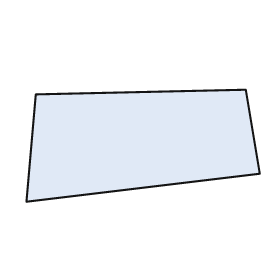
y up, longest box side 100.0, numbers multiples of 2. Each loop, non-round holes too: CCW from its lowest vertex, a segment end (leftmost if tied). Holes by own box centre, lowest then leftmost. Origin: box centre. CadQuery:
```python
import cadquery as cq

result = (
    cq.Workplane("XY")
    .moveTo(-50.0, -24.0)
    .lineTo(50.0, -12.0)
    .lineTo(44.0, 24.0)
    .lineTo(-46.0, 22.0)
    .close()
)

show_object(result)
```